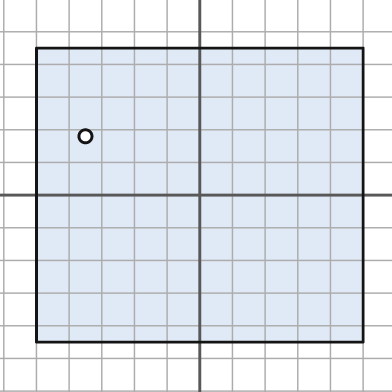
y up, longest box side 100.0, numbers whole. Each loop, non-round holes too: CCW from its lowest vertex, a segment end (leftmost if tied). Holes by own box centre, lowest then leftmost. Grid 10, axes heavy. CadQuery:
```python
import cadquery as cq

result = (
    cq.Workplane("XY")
    .moveTo(-50.0, -45.0)
    .lineTo(50.0, -45.0)
    .lineTo(50.0, 45.0)
    .lineTo(-50.0, 45.0)
    .close()
    .moveTo(-35.0, 18.0)
    .circle(2.0)
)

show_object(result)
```